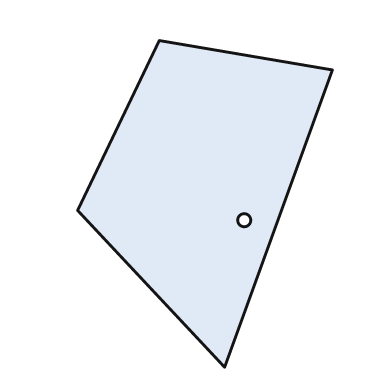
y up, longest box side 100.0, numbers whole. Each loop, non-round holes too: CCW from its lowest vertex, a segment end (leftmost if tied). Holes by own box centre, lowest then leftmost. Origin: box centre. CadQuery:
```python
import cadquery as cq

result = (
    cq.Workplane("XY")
    .moveTo(6.0, -50.0)
    .lineTo(39.0, 41.0)
    .lineTo(-14.0, 50.0)
    .lineTo(-39.0, -2.0)
    .close()
    .moveTo(12.0, -5.0)
    .circle(2.0)
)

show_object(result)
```